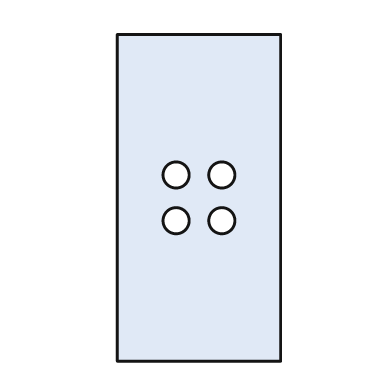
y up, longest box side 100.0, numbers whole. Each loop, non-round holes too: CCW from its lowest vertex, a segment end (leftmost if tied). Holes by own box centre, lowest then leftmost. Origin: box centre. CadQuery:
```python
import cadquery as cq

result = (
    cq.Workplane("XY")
    .moveTo(-25.0, -50.0)
    .lineTo(25.0, -50.0)
    .lineTo(25.0, 50.0)
    .lineTo(-25.0, 50.0)
    .close()
    .moveTo(-7.0, -7.0)
    .circle(4.0)
    .moveTo(7.0, -7.0)
    .circle(4.0)
    .moveTo(-7.0, 7.0)
    .circle(4.0)
    .moveTo(7.0, 7.0)
    .circle(4.0)
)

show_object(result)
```